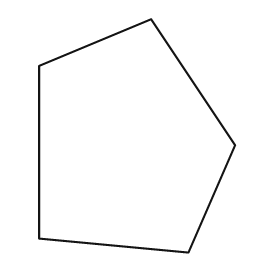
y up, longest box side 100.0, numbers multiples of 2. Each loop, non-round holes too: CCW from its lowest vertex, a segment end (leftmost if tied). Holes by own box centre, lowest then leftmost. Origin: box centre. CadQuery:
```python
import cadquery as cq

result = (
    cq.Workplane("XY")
    .moveTo(22.0, -50.0)
    .lineTo(42.0, -4.0)
    .lineTo(6.0, 50.0)
    .lineTo(-42.0, 30.0)
    .lineTo(-42.0, -44.0)
    .close()
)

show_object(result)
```